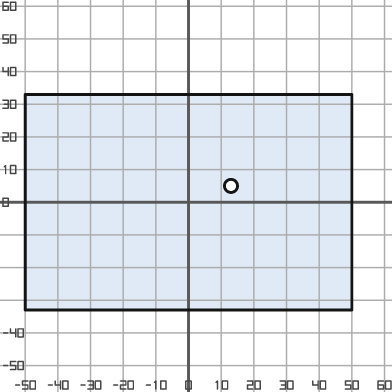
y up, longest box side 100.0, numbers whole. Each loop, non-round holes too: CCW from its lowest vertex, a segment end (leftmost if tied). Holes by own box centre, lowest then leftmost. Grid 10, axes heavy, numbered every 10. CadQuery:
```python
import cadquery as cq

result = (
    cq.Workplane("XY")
    .moveTo(-50.0, -33.0)
    .lineTo(50.0, -33.0)
    .lineTo(50.0, 33.0)
    .lineTo(-50.0, 33.0)
    .close()
    .moveTo(13.0, 5.0)
    .circle(2.0)
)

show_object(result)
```